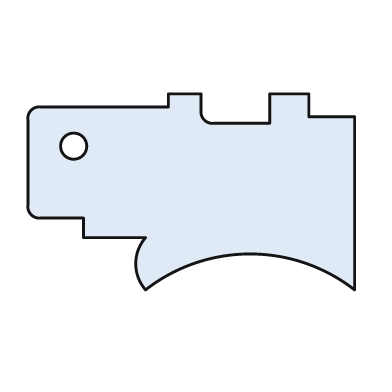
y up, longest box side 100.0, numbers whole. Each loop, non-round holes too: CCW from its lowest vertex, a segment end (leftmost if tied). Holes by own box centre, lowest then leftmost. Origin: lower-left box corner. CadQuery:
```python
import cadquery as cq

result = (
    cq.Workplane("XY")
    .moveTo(36.0, 0.0)
    .threePointArc((68.0, 11.0), (100.0, 0.0))
    .lineTo(100.0, 53.0)
    .lineTo(86.0, 53.0)
    .lineTo(86.0, 60.0)
    .lineTo(74.0, 60.0)
    .lineTo(74.0, 51.0)
    .lineTo(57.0, 51.0)
    .threePointArc((54.0, 52.0), (53.0, 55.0))
    .lineTo(53.0, 60.0)
    .lineTo(43.0, 60.0)
    .lineTo(43.0, 56.0)
    .lineTo(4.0, 56.0)
    .threePointArc((1.0, 55.0), (0.0, 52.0))
    .lineTo(0.0, 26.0)
    .threePointArc((1.0, 23.0), (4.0, 22.0))
    .lineTo(17.0, 22.0)
    .lineTo(17.0, 16.0)
    .lineTo(36.0, 16.0)
    .threePointArc((33.0, 8.0), (36.0, 0.0))
    .close()
    .moveTo(14.0, 44.0)
    .circle(4.0)
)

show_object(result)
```